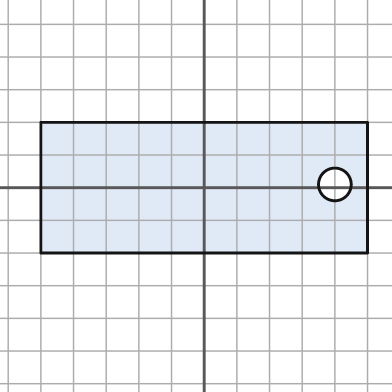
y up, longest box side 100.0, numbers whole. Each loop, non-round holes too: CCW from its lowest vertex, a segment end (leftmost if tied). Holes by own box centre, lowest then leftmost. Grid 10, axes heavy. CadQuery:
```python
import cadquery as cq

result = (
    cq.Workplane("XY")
    .moveTo(-50.0, -20.0)
    .lineTo(50.0, -20.0)
    .lineTo(50.0, 20.0)
    .lineTo(-50.0, 20.0)
    .close()
    .moveTo(40.0, 1.0)
    .circle(5.0)
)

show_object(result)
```